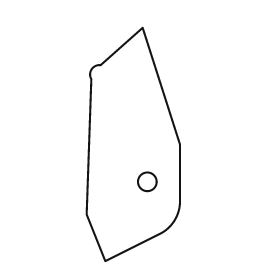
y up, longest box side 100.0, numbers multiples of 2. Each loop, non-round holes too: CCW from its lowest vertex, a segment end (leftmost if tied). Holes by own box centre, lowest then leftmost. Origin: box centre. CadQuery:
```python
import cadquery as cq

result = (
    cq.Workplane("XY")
    .moveTo(-12.0, -50.0)
    .lineTo(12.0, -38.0)
    .threePointArc((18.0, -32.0), (20.0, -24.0))
    .lineTo(20.0, 0.0)
    .lineTo(4.0, 50.0)
    .lineTo(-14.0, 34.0)
    .threePointArc((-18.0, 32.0), (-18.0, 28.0))
    .lineTo(-20.0, -30.0)
    .close()
    .moveTo(6.0, -16.0)
    .circle(4.0)
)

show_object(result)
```